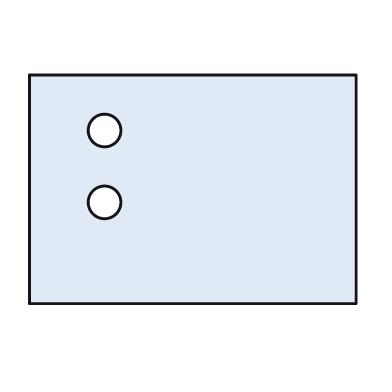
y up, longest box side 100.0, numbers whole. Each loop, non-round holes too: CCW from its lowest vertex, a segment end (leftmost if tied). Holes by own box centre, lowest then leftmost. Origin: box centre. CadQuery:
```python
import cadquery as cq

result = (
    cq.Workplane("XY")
    .moveTo(-50.0, -35.0)
    .lineTo(50.0, -35.0)
    .lineTo(50.0, 35.0)
    .lineTo(-50.0, 35.0)
    .close()
    .moveTo(-27.0, -4.0)
    .circle(5.0)
    .moveTo(-27.0, 18.0)
    .circle(5.0)
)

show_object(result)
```